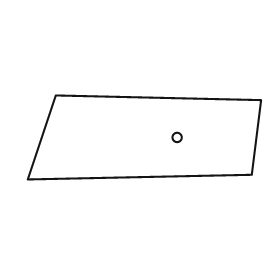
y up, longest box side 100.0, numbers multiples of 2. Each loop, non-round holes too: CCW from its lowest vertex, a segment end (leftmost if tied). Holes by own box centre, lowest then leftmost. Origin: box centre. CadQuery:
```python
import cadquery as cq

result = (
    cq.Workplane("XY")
    .moveTo(-50.0, -18.0)
    .lineTo(46.0, -16.0)
    .lineTo(50.0, 16.0)
    .lineTo(-38.0, 18.0)
    .close()
    .moveTo(14.0, 0.0)
    .circle(2.0)
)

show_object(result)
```